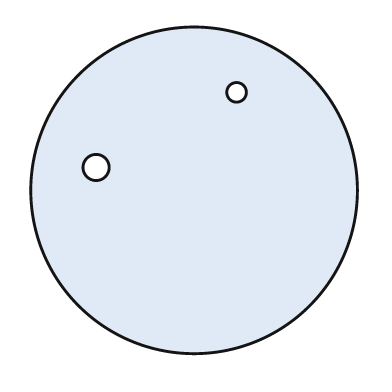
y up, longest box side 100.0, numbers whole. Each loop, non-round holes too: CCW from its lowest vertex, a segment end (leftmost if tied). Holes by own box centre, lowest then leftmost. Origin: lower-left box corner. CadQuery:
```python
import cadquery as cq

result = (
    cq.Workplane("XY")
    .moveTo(50.0, 50.0)
    .circle(50.0)
    .moveTo(20.0, 57.0)
    .circle(4.0)
    .moveTo(63.0, 80.0)
    .circle(3.0)
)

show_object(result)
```